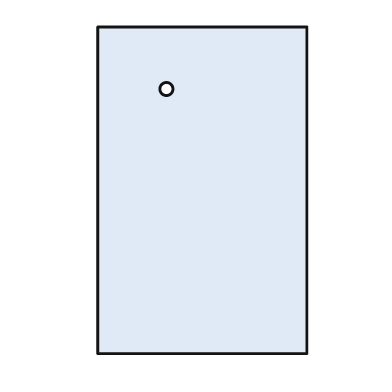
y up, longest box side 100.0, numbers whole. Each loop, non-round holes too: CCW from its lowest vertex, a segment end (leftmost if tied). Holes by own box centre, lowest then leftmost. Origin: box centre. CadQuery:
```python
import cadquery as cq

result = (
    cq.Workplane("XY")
    .moveTo(-32.0, -50.0)
    .lineTo(32.0, -50.0)
    .lineTo(32.0, 50.0)
    .lineTo(-32.0, 50.0)
    .close()
    .moveTo(-11.0, 31.0)
    .circle(2.0)
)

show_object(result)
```